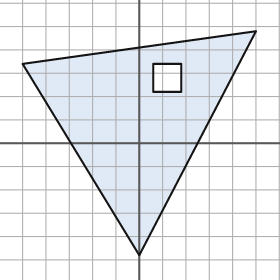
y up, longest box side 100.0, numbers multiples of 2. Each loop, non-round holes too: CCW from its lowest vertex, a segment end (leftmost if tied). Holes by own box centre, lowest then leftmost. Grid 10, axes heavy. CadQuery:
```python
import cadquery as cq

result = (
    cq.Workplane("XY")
    .moveTo(0.0, -48.0)
    .lineTo(50.0, 48.0)
    .lineTo(-50.0, 34.0)
    .close()
    .moveTo(6.0, 22.0)
    .lineTo(18.0, 22.0)
    .lineTo(18.0, 34.0)
    .lineTo(6.0, 34.0)
    .close()
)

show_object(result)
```